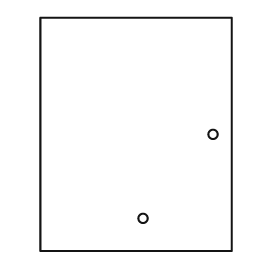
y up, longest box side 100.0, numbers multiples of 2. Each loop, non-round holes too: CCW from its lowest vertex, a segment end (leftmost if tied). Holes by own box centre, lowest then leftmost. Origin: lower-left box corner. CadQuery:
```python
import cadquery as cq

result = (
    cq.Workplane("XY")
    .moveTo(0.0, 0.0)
    .lineTo(82.0, 0.0)
    .lineTo(82.0, 100.0)
    .lineTo(0.0, 100.0)
    .close()
    .moveTo(44.0, 14.0)
    .circle(2.0)
    .moveTo(74.0, 50.0)
    .circle(2.0)
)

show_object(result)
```